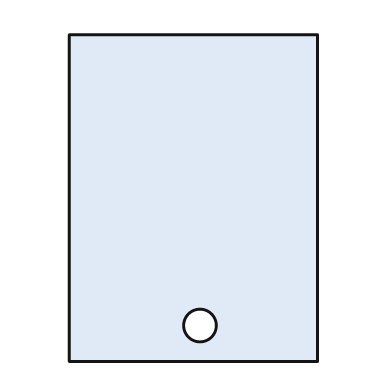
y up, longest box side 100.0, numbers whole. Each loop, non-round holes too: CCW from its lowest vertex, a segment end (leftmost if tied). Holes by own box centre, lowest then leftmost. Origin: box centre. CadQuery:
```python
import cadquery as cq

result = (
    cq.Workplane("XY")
    .moveTo(-38.0, -50.0)
    .lineTo(38.0, -50.0)
    .lineTo(38.0, 50.0)
    .lineTo(-38.0, 50.0)
    .close()
    .moveTo(2.0, -39.0)
    .circle(5.0)
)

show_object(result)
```